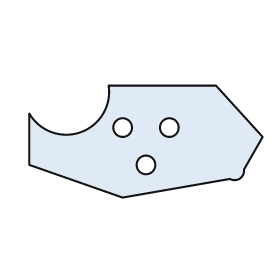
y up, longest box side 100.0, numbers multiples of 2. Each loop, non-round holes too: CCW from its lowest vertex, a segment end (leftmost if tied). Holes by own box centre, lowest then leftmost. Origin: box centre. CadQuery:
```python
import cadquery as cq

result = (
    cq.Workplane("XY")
    .moveTo(-10.0, -24.0)
    .lineTo(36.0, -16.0)
    .threePointArc((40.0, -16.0), (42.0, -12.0))
    .lineTo(50.0, 2.0)
    .lineTo(30.0, 24.0)
    .lineTo(-16.0, 24.0)
    .threePointArc((-28.0, 4.0), (-50.0, 12.0))
    .lineTo(-50.0, -10.0)
    .close()
    .moveTo(0.0, -10.0)
    .circle(4.0)
    .moveTo(-10.0, 6.0)
    .circle(4.0)
    .moveTo(10.0, 6.0)
    .circle(4.0)
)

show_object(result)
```